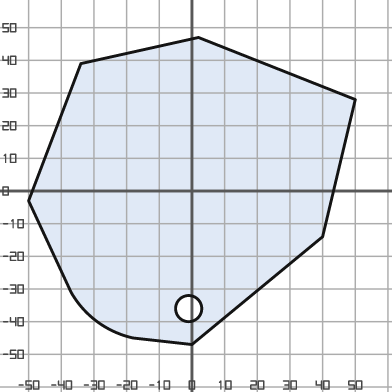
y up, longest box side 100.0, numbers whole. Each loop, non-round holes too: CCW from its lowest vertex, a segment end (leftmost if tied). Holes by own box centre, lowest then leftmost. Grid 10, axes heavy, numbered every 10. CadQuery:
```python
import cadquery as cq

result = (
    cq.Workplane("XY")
    .moveTo(0.0, -47.0)
    .lineTo(40.0, -14.0)
    .lineTo(50.0, 28.0)
    .lineTo(2.0, 47.0)
    .lineTo(-34.0, 39.0)
    .lineTo(-50.0, -3.0)
    .lineTo(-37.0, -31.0)
    .threePointArc((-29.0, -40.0), (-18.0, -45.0))
    .close()
    .moveTo(-1.0, -36.0)
    .circle(4.0)
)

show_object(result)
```